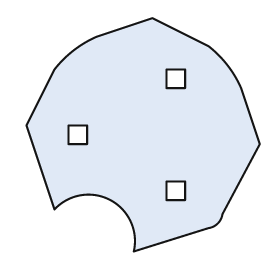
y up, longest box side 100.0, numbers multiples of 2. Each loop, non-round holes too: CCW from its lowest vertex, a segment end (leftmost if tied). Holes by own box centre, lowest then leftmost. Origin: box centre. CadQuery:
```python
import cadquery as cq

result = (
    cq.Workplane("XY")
    .moveTo(-4.0, -50.0)
    .lineTo(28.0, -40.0)
    .threePointArc((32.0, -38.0), (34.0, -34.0))
    .lineTo(50.0, -4.0)
    .lineTo(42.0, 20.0)
    .threePointArc((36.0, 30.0), (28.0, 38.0))
    .lineTo(4.0, 50.0)
    .lineTo(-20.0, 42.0)
    .threePointArc((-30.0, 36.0), (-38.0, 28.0))
    .lineTo(-50.0, 4.0)
    .lineTo(-38.0, -32.0)
    .threePointArc((-14.0, -28.0), (-4.0, -50.0))
    .close()
    .moveTo(10.0, -28.0)
    .lineTo(18.0, -28.0)
    .lineTo(18.0, -20.0)
    .lineTo(10.0, -20.0)
    .close()
    .moveTo(-32.0, -4.0)
    .lineTo(-24.0, -4.0)
    .lineTo(-24.0, 4.0)
    .lineTo(-32.0, 4.0)
    .close()
    .moveTo(10.0, 20.0)
    .lineTo(18.0, 20.0)
    .lineTo(18.0, 28.0)
    .lineTo(10.0, 28.0)
    .close()
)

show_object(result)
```